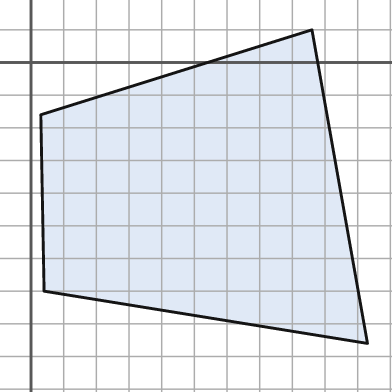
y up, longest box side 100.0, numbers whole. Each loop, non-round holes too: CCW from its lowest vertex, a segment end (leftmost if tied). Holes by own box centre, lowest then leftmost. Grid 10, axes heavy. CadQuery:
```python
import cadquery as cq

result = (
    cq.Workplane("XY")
    .moveTo(103.0, -86.0)
    .lineTo(86.0, 10.0)
    .lineTo(3.0, -16.0)
    .lineTo(4.0, -70.0)
    .close()
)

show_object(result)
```